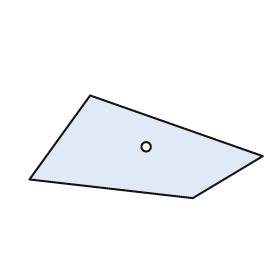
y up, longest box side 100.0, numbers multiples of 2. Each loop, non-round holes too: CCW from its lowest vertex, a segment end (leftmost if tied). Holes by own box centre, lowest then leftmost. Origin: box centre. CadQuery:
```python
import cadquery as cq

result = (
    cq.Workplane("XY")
    .moveTo(20.0, -22.0)
    .lineTo(50.0, -4.0)
    .lineTo(-24.0, 22.0)
    .lineTo(-50.0, -14.0)
    .close()
    .moveTo(0.0, 0.0)
    .circle(2.0)
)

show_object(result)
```